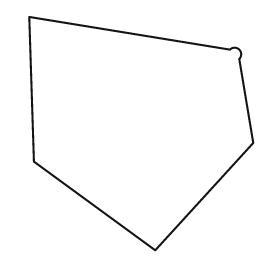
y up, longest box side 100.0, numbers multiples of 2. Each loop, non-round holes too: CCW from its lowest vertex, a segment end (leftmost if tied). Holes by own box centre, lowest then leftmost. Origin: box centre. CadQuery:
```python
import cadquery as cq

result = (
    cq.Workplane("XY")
    .moveTo(6.0, -50.0)
    .lineTo(48.0, -4.0)
    .lineTo(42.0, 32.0)
    .threePointArc((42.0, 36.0), (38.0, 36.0))
    .lineTo(-48.0, 50.0)
    .lineTo(-46.0, -12.0)
    .close()
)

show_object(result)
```